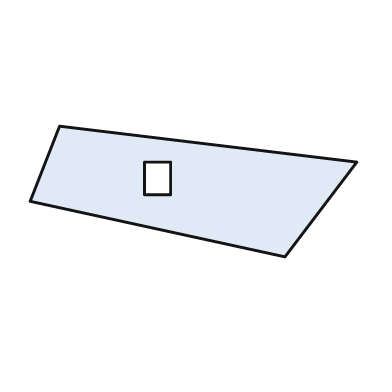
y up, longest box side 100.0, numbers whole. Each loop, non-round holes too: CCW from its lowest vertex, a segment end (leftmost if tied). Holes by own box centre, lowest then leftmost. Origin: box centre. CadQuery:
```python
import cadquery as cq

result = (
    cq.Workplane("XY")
    .moveTo(28.0, -20.0)
    .lineTo(50.0, 9.0)
    .lineTo(-41.0, 20.0)
    .lineTo(-50.0, -3.0)
    .close()
    .moveTo(-15.0, -1.0)
    .lineTo(-7.0, -1.0)
    .lineTo(-7.0, 9.0)
    .lineTo(-15.0, 9.0)
    .close()
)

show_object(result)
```